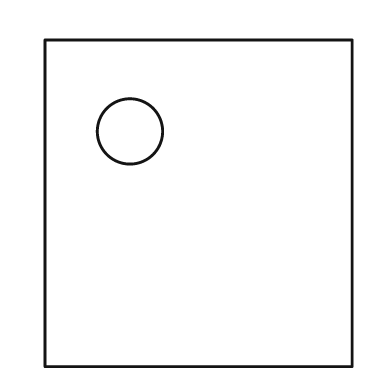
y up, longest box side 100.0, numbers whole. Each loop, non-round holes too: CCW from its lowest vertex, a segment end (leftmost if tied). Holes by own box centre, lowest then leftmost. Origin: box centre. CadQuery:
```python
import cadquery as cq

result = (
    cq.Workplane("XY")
    .moveTo(-47.0, -50.0)
    .lineTo(47.0, -50.0)
    .lineTo(47.0, 50.0)
    .lineTo(-47.0, 50.0)
    .close()
    .moveTo(-21.0, 22.0)
    .circle(10.0)
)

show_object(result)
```